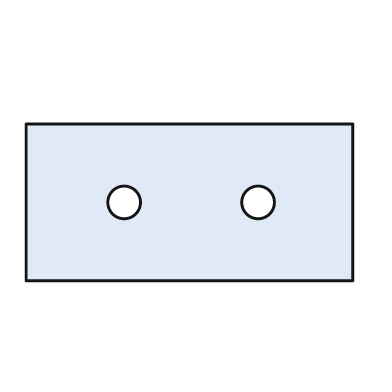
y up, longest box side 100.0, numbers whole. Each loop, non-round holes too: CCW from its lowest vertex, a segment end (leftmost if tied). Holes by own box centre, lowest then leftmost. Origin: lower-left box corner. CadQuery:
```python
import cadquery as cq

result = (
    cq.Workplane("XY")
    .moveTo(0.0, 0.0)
    .lineTo(100.0, 0.0)
    .lineTo(100.0, 48.0)
    .lineTo(0.0, 48.0)
    .close()
    .moveTo(30.0, 24.0)
    .circle(5.0)
    .moveTo(71.0, 24.0)
    .circle(5.0)
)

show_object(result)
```